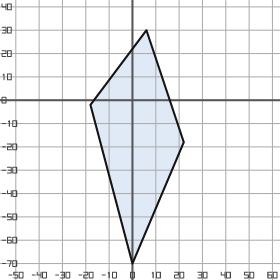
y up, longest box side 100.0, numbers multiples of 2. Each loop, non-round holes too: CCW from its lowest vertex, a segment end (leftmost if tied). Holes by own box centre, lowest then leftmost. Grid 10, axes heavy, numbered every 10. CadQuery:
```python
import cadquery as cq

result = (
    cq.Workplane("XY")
    .moveTo(0.0, -70.0)
    .lineTo(22.0, -18.0)
    .lineTo(6.0, 30.0)
    .lineTo(-18.0, -2.0)
    .close()
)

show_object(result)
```